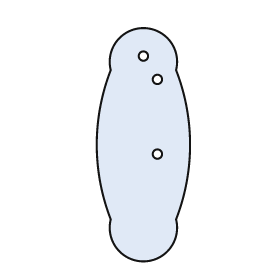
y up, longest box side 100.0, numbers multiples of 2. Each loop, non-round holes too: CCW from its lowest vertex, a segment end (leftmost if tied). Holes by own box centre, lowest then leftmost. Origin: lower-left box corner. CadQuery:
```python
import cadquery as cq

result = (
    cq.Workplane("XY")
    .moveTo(6.0, 18.0)
    .threePointArc((20.0, 0.0), (34.0, 18.0))
    .threePointArc((40.0, 50.0), (34.0, 82.0))
    .threePointArc((20.0, 100.0), (6.0, 82.0))
    .threePointArc((0.0, 50.0), (6.0, 18.0))
    .close()
    .moveTo(26.0, 46.0)
    .circle(2.0)
    .moveTo(26.0, 78.0)
    .circle(2.0)
    .moveTo(20.0, 88.0)
    .circle(2.0)
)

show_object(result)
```